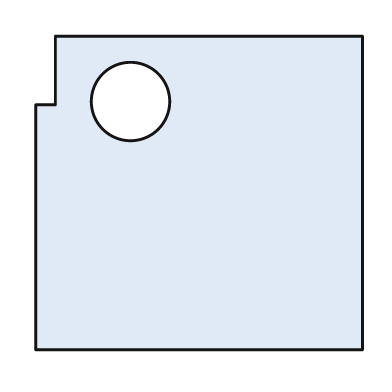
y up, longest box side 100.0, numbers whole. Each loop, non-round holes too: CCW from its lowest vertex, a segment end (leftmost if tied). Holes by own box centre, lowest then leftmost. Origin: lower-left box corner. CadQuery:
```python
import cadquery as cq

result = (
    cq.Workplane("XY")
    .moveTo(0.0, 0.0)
    .lineTo(100.0, 0.0)
    .lineTo(100.0, 96.0)
    .lineTo(6.0, 96.0)
    .lineTo(6.0, 75.0)
    .lineTo(0.0, 75.0)
    .close()
    .moveTo(29.0, 76.0)
    .circle(12.0)
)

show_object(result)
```